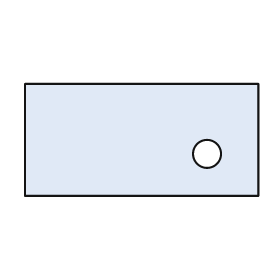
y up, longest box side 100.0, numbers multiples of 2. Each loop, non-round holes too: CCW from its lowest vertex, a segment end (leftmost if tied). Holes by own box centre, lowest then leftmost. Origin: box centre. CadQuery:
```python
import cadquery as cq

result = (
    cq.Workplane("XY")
    .moveTo(-50.0, -24.0)
    .lineTo(50.0, -24.0)
    .lineTo(50.0, 24.0)
    .lineTo(-50.0, 24.0)
    .close()
    .moveTo(28.0, -6.0)
    .circle(6.0)
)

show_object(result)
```